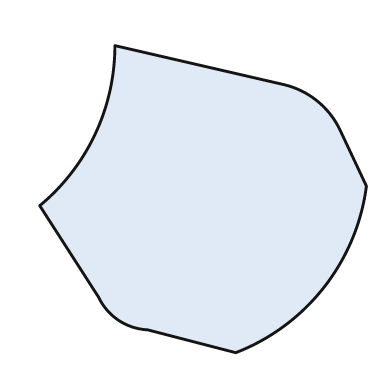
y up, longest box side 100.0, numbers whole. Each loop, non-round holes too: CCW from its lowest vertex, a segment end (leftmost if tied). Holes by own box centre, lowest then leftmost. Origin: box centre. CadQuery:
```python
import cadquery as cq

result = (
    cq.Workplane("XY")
    .moveTo(10.0, -47.0)
    .threePointArc((37.0, -27.0), (50.0, 4.0))
    .lineTo(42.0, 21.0)
    .threePointArc((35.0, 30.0), (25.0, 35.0))
    .lineTo(-27.0, 47.0)
    .threePointArc((-33.0, 20.0), (-50.0, -2.0))
    .lineTo(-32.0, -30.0)
    .threePointArc((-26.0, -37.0), (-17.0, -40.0))
    .close()
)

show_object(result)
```